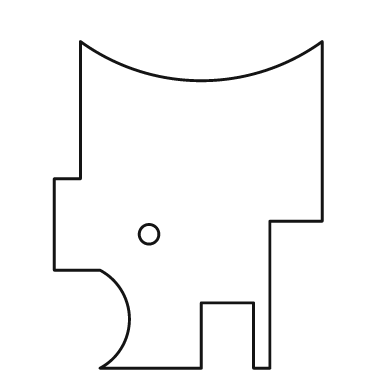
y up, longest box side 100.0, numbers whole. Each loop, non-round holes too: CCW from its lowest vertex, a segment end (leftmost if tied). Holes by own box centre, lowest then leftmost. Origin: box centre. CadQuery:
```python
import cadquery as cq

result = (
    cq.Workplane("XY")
    .moveTo(-27.0, -50.0)
    .lineTo(4.0, -50.0)
    .lineTo(4.0, -30.0)
    .lineTo(20.0, -30.0)
    .lineTo(20.0, -50.0)
    .lineTo(25.0, -50.0)
    .lineTo(25.0, -5.0)
    .lineTo(41.0, -5.0)
    .lineTo(41.0, 50.0)
    .threePointArc((4.0, 38.0), (-33.0, 50.0))
    .lineTo(-33.0, 8.0)
    .lineTo(-41.0, 8.0)
    .lineTo(-41.0, -20.0)
    .lineTo(-27.0, -20.0)
    .threePointArc((-18.0, -35.0), (-27.0, -50.0))
    .close()
    .moveTo(-12.0, -9.0)
    .circle(3.0)
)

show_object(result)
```